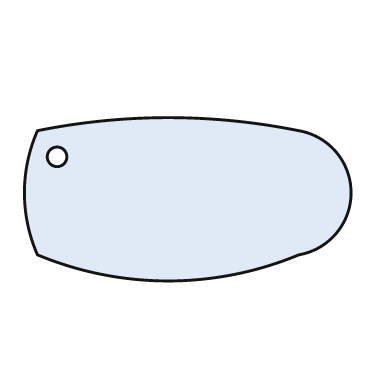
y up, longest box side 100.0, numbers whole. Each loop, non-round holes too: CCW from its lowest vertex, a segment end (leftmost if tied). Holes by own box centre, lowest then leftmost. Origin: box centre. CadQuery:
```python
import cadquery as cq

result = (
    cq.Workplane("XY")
    .moveTo(-46.0, -17.0)
    .threePointArc((-6.0, -25.0), (34.0, -17.0))
    .threePointArc((50.0, 2.0), (34.0, 21.0))
    .threePointArc((-6.0, 25.0), (-46.0, 21.0))
    .threePointArc((-50.0, 2.0), (-46.0, -17.0))
    .close()
    .moveTo(-40.0, 13.0)
    .circle(3.0)
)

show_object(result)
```